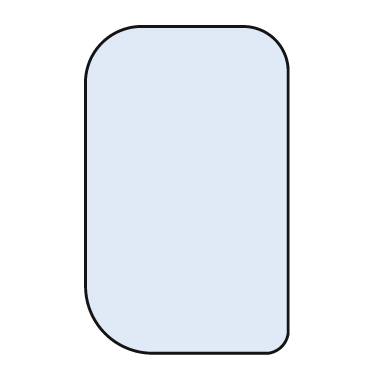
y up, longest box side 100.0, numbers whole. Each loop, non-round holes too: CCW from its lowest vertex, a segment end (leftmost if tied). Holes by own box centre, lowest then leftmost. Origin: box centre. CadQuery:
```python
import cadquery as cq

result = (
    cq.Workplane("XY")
    .moveTo(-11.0, -50.0)
    .lineTo(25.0, -50.0)
    .threePointArc((29.0, -48.0), (31.0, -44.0))
    .lineTo(31.0, 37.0)
    .threePointArc((27.0, 46.0), (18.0, 50.0))
    .lineTo(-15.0, 50.0)
    .threePointArc((-26.0, 45.0), (-31.0, 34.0))
    .lineTo(-31.0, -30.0)
    .threePointArc((-25.0, -44.0), (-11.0, -50.0))
    .close()
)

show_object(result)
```